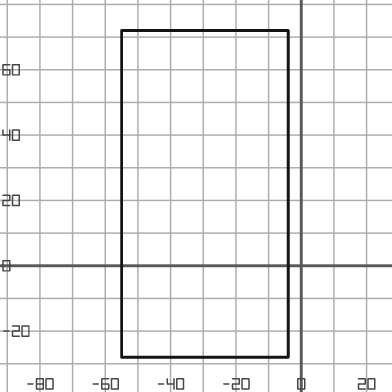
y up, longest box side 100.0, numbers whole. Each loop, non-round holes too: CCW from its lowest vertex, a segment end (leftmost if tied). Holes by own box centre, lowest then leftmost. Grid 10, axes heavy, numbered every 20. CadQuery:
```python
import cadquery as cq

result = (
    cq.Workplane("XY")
    .moveTo(-55.0, -28.0)
    .lineTo(-4.0, -28.0)
    .lineTo(-4.0, 72.0)
    .lineTo(-55.0, 72.0)
    .close()
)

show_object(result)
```